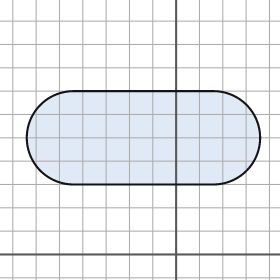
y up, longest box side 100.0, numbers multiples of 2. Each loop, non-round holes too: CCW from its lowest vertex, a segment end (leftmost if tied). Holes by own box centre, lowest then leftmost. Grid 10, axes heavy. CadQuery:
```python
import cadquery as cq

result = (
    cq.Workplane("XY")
    .moveTo(-44.0, 30.0)
    .lineTo(16.0, 30.0)
    .threePointArc((36.0, 50.0), (16.0, 70.0))
    .lineTo(-44.0, 70.0)
    .threePointArc((-64.0, 50.0), (-44.0, 30.0))
    .close()
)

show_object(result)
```